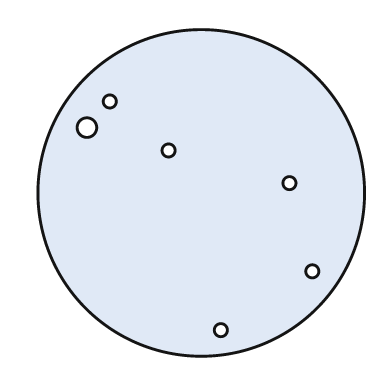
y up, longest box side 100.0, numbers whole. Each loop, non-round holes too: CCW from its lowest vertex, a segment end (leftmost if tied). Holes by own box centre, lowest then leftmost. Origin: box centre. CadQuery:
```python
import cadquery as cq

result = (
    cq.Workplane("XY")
    .moveTo(0.0, 0.0)
    .circle(50.0)
    .moveTo(6.0, -42.0)
    .circle(2.0)
    .moveTo(34.0, -24.0)
    .circle(2.0)
    .moveTo(27.0, 3.0)
    .circle(2.0)
    .moveTo(-10.0, 13.0)
    .circle(2.0)
    .moveTo(-35.0, 20.0)
    .circle(3.0)
    .moveTo(-28.0, 28.0)
    .circle(2.0)
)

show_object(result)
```